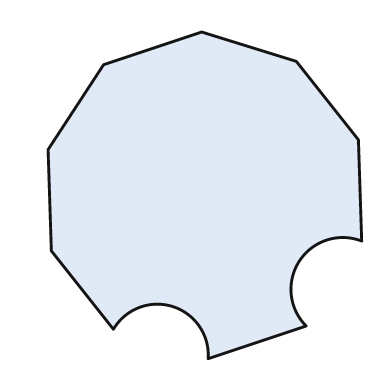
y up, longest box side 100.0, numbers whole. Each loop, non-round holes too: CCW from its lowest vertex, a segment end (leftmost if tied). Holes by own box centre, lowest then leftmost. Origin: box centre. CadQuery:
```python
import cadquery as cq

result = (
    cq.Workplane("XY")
    .moveTo(1.0, -50.0)
    .lineTo(31.0, -40.0)
    .threePointArc((29.0, -20.0), (48.0, -14.0))
    .lineTo(47.0, 17.0)
    .lineTo(28.0, 41.0)
    .lineTo(-1.0, 50.0)
    .lineTo(-31.0, 40.0)
    .lineTo(-48.0, 14.0)
    .lineTo(-47.0, -17.0)
    .lineTo(-28.0, -41.0)
    .threePointArc((-10.0, -34.0), (1.0, -50.0))
    .close()
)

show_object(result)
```